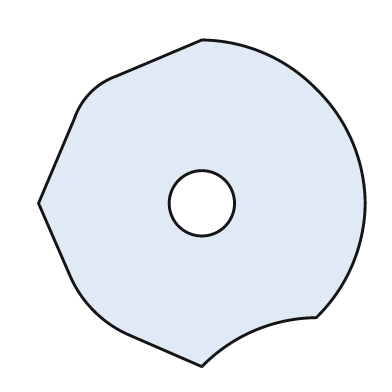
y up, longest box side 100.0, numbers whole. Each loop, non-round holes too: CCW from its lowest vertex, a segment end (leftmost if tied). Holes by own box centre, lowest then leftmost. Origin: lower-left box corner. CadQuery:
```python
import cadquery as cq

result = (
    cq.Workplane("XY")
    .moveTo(50.0, 0.0)
    .threePointArc((66.0, 11.0), (85.0, 15.0))
    .threePointArc((96.0, 31.0), (100.0, 50.0))
    .threePointArc((96.0, 69.0), (85.0, 85.0))
    .threePointArc((69.0, 96.0), (50.0, 100.0))
    .lineTo(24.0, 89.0)
    .threePointArc((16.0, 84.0), (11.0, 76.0))
    .lineTo(0.0, 50.0)
    .lineTo(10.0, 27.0)
    .threePointArc((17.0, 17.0), (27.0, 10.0))
    .close()
    .moveTo(50.0, 50.0)
    .circle(10.0)
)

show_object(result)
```